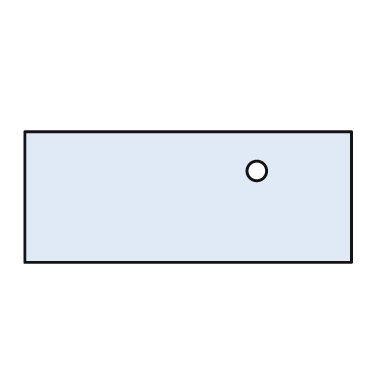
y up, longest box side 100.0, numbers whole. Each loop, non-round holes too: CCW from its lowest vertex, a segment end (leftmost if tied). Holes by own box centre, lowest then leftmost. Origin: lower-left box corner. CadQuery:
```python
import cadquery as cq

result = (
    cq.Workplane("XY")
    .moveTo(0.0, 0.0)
    .lineTo(100.0, 0.0)
    .lineTo(100.0, 40.0)
    .lineTo(0.0, 40.0)
    .close()
    .moveTo(71.0, 28.0)
    .circle(3.0)
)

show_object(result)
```